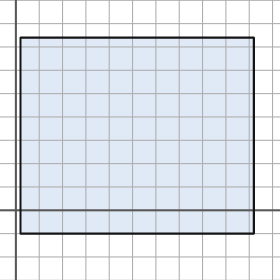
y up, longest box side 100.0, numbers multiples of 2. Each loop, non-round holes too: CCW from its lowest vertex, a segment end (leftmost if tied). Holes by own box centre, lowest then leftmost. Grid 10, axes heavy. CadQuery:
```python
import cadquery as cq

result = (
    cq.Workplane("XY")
    .moveTo(2.0, -10.0)
    .lineTo(102.0, -10.0)
    .lineTo(102.0, 74.0)
    .lineTo(2.0, 74.0)
    .close()
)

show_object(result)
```